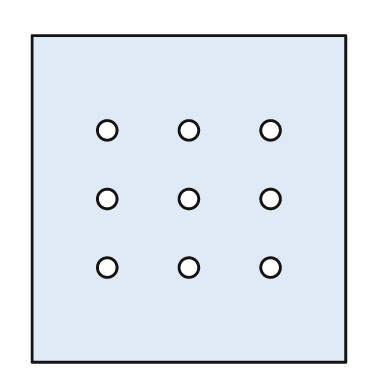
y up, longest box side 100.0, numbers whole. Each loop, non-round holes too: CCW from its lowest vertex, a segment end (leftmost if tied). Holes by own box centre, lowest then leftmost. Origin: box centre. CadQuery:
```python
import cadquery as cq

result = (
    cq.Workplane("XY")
    .moveTo(-48.0, -50.0)
    .lineTo(48.0, -50.0)
    .lineTo(48.0, 50.0)
    .lineTo(-48.0, 50.0)
    .close()
    .moveTo(-25.0, -21.0)
    .circle(3.0)
    .moveTo(0.0, -21.0)
    .circle(3.0)
    .moveTo(25.0, -21.0)
    .circle(3.0)
    .moveTo(-25.0, 0.0)
    .circle(3.0)
    .moveTo(0.0, 0.0)
    .circle(3.0)
    .moveTo(25.0, 0.0)
    .circle(3.0)
    .moveTo(-25.0, 21.0)
    .circle(3.0)
    .moveTo(0.0, 21.0)
    .circle(3.0)
    .moveTo(25.0, 21.0)
    .circle(3.0)
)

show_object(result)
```